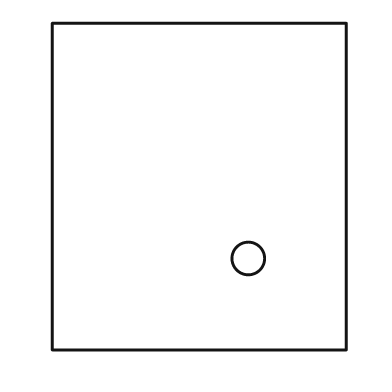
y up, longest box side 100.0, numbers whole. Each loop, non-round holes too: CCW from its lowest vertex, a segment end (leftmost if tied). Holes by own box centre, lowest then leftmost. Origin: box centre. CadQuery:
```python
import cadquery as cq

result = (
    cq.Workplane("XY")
    .moveTo(-45.0, -50.0)
    .lineTo(45.0, -50.0)
    .lineTo(45.0, 50.0)
    .lineTo(-45.0, 50.0)
    .close()
    .moveTo(15.0, -22.0)
    .circle(5.0)
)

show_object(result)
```